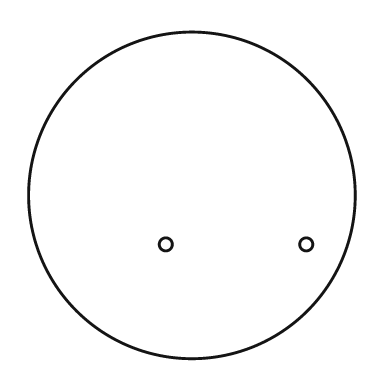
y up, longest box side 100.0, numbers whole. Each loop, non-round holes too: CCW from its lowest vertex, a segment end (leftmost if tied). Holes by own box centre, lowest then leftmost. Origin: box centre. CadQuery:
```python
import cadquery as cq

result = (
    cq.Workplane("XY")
    .moveTo(0.0, 0.0)
    .circle(50.0)
    .moveTo(-8.0, -15.0)
    .circle(2.0)
    .moveTo(35.0, -15.0)
    .circle(2.0)
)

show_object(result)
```